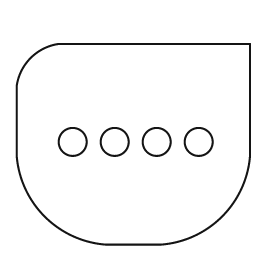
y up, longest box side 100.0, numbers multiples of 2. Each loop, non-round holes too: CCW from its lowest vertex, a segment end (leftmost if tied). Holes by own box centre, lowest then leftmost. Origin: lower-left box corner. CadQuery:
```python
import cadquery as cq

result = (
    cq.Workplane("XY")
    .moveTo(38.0, 0.0)
    .lineTo(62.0, 0.0)
    .threePointArc((88.0, 12.0), (100.0, 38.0))
    .lineTo(100.0, 86.0)
    .lineTo(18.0, 86.0)
    .threePointArc((6.0, 80.0), (0.0, 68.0))
    .lineTo(0.0, 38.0)
    .threePointArc((12.0, 12.0), (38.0, 0.0))
    .close()
    .moveTo(24.0, 44.0)
    .circle(6.0)
    .moveTo(42.0, 44.0)
    .circle(6.0)
    .moveTo(60.0, 44.0)
    .circle(6.0)
    .moveTo(78.0, 44.0)
    .circle(6.0)
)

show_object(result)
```